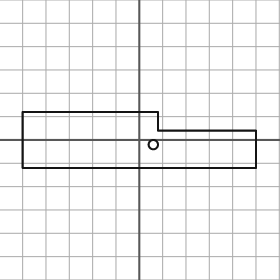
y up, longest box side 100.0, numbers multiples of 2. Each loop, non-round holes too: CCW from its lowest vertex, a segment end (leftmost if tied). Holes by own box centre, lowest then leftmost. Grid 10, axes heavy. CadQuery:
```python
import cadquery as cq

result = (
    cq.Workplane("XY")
    .moveTo(-50.0, -12.0)
    .lineTo(50.0, -12.0)
    .lineTo(50.0, 4.0)
    .lineTo(8.0, 4.0)
    .lineTo(8.0, 12.0)
    .lineTo(-50.0, 12.0)
    .close()
    .moveTo(6.0, -2.0)
    .circle(2.0)
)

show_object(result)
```